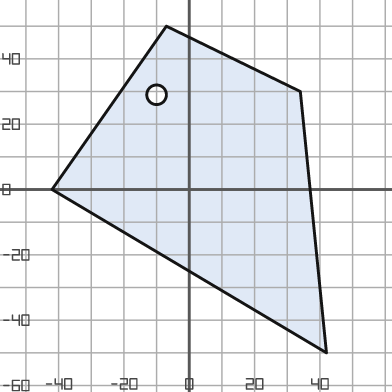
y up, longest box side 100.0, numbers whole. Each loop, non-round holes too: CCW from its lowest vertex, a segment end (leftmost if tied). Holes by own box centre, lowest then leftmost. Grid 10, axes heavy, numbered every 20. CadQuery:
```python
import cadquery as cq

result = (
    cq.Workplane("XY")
    .moveTo(42.0, -50.0)
    .lineTo(34.0, 30.0)
    .lineTo(-7.0, 50.0)
    .lineTo(-42.0, 0.0)
    .close()
    .moveTo(-10.0, 29.0)
    .circle(3.0)
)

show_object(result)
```